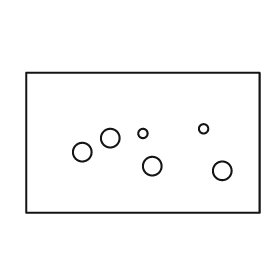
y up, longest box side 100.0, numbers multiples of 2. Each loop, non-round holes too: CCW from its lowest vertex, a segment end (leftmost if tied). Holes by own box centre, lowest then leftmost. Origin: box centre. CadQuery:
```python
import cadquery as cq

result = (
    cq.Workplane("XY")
    .moveTo(-50.0, -30.0)
    .lineTo(50.0, -30.0)
    .lineTo(50.0, 30.0)
    .lineTo(-50.0, 30.0)
    .close()
    .moveTo(34.0, -12.0)
    .circle(4.0)
    .moveTo(4.0, -10.0)
    .circle(4.0)
    .moveTo(-26.0, -4.0)
    .circle(4.0)
    .moveTo(-14.0, 2.0)
    .circle(4.0)
    .moveTo(0.0, 4.0)
    .circle(2.0)
    .moveTo(26.0, 6.0)
    .circle(2.0)
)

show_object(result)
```